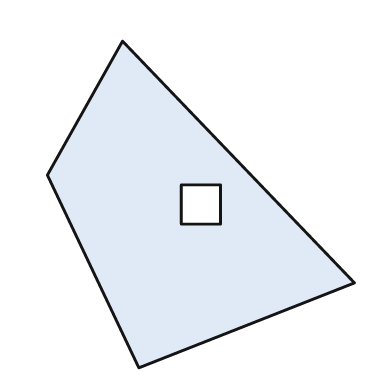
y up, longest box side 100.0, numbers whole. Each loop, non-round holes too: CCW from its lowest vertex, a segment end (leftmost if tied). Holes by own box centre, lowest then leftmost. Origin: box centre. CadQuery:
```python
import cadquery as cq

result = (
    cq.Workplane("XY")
    .moveTo(-19.0, -50.0)
    .lineTo(47.0, -24.0)
    .lineTo(-24.0, 50.0)
    .lineTo(-47.0, 9.0)
    .close()
    .moveTo(-6.0, -6.0)
    .lineTo(6.0, -6.0)
    .lineTo(6.0, 6.0)
    .lineTo(-6.0, 6.0)
    .close()
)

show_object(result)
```